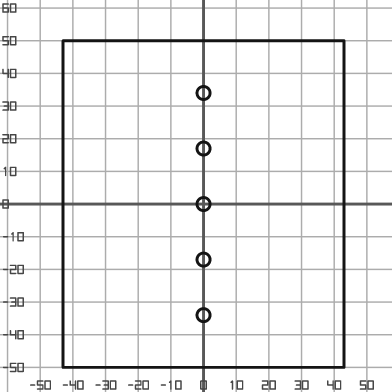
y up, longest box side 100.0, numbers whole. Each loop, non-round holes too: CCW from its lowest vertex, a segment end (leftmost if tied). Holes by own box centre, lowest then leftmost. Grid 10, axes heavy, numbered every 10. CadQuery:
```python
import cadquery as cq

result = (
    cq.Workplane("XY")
    .moveTo(-43.0, -50.0)
    .lineTo(43.0, -50.0)
    .lineTo(43.0, 50.0)
    .lineTo(-43.0, 50.0)
    .close()
    .moveTo(0.0, -34.0)
    .circle(2.0)
    .moveTo(0.0, -17.0)
    .circle(2.0)
    .moveTo(0.0, 0.0)
    .circle(2.0)
    .moveTo(0.0, 17.0)
    .circle(2.0)
    .moveTo(0.0, 34.0)
    .circle(2.0)
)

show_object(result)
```